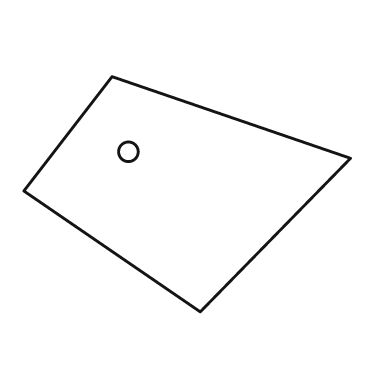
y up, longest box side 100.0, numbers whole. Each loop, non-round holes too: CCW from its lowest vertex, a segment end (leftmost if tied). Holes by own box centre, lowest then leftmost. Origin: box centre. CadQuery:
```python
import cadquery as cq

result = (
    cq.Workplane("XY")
    .moveTo(4.0, -36.0)
    .lineTo(50.0, 11.0)
    .lineTo(-23.0, 36.0)
    .lineTo(-50.0, 1.0)
    .close()
    .moveTo(-18.0, 13.0)
    .circle(3.0)
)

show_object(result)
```